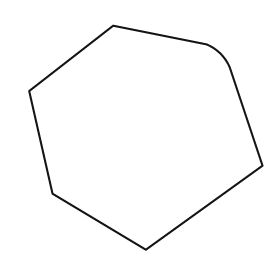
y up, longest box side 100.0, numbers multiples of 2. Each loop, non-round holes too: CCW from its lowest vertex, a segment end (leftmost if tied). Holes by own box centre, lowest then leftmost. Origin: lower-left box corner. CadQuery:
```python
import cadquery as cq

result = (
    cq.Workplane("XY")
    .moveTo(50.0, 0.0)
    .lineTo(100.0, 36.0)
    .lineTo(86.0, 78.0)
    .threePointArc((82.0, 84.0), (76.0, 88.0))
    .lineTo(36.0, 96.0)
    .lineTo(0.0, 68.0)
    .lineTo(10.0, 24.0)
    .close()
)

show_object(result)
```